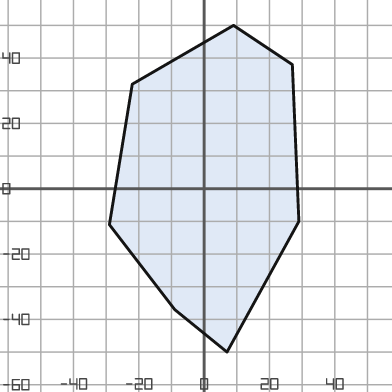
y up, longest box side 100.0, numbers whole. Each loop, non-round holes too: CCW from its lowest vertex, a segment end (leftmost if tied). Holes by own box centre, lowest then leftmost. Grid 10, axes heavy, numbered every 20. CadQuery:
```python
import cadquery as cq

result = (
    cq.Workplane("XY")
    .moveTo(7.0, -50.0)
    .lineTo(29.0, -10.0)
    .lineTo(27.0, 38.0)
    .lineTo(9.0, 50.0)
    .lineTo(-22.0, 32.0)
    .lineTo(-29.0, -11.0)
    .lineTo(-9.0, -37.0)
    .close()
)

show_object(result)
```